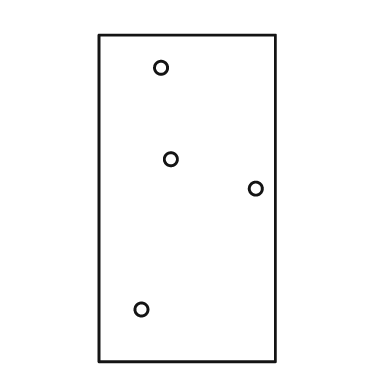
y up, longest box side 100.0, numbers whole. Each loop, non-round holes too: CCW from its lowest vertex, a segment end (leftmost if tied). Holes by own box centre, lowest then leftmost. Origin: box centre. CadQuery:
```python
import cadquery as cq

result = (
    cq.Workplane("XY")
    .moveTo(-27.0, -50.0)
    .lineTo(27.0, -50.0)
    .lineTo(27.0, 50.0)
    .lineTo(-27.0, 50.0)
    .close()
    .moveTo(-14.0, -34.0)
    .circle(2.0)
    .moveTo(21.0, 3.0)
    .circle(2.0)
    .moveTo(-5.0, 12.0)
    .circle(2.0)
    .moveTo(-8.0, 40.0)
    .circle(2.0)
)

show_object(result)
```